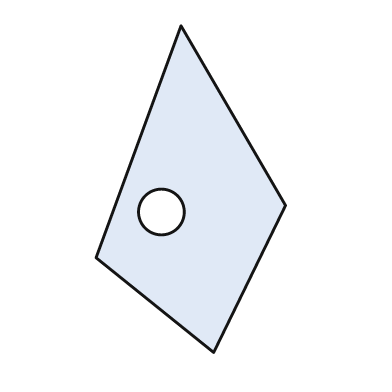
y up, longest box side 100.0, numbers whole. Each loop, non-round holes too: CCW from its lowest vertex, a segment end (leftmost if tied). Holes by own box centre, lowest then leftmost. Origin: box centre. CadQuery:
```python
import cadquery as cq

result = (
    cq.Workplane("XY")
    .moveTo(7.0, -50.0)
    .lineTo(29.0, -5.0)
    .lineTo(-3.0, 50.0)
    .lineTo(-29.0, -21.0)
    .close()
    .moveTo(-9.0, -7.0)
    .circle(7.0)
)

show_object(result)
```